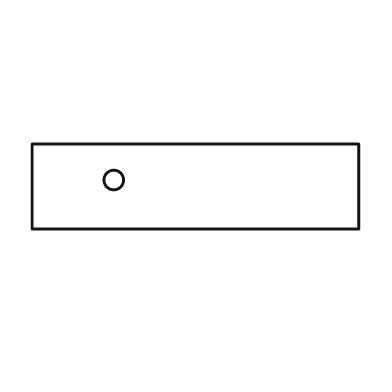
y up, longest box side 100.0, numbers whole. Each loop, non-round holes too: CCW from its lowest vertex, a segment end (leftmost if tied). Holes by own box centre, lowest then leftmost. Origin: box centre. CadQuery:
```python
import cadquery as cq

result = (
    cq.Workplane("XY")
    .moveTo(-50.0, -13.0)
    .lineTo(50.0, -13.0)
    .lineTo(50.0, 13.0)
    .lineTo(-50.0, 13.0)
    .close()
    .moveTo(-25.0, 2.0)
    .circle(3.0)
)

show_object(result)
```